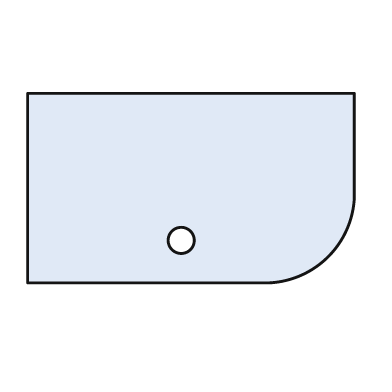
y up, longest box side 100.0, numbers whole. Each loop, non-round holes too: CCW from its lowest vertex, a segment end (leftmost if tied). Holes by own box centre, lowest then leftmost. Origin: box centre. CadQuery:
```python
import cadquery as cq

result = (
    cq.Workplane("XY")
    .moveTo(-50.0, -29.0)
    .lineTo(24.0, -29.0)
    .threePointArc((42.0, -21.0), (50.0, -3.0))
    .lineTo(50.0, 29.0)
    .lineTo(-50.0, 29.0)
    .close()
    .moveTo(-3.0, -16.0)
    .circle(4.0)
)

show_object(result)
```